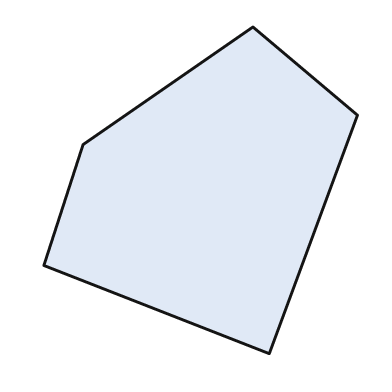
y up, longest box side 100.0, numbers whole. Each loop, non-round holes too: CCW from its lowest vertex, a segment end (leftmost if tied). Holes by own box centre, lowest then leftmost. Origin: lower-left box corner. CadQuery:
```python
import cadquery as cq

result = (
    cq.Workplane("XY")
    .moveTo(69.0, 0.0)
    .lineTo(96.0, 73.0)
    .lineTo(64.0, 100.0)
    .lineTo(12.0, 64.0)
    .lineTo(0.0, 27.0)
    .close()
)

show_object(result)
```